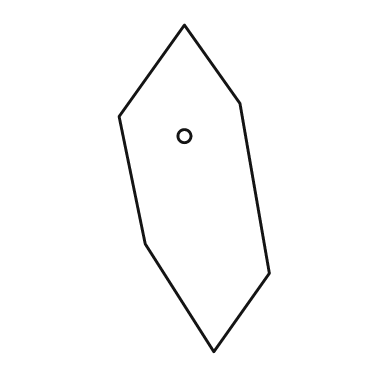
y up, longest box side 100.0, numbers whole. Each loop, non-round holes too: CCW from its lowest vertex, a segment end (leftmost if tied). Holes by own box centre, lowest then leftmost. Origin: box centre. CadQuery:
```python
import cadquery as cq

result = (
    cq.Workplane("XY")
    .moveTo(6.0, -50.0)
    .lineTo(23.0, -26.0)
    .lineTo(14.0, 26.0)
    .lineTo(-3.0, 50.0)
    .lineTo(-23.0, 22.0)
    .lineTo(-15.0, -17.0)
    .close()
    .moveTo(-3.0, 16.0)
    .circle(2.0)
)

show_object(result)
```